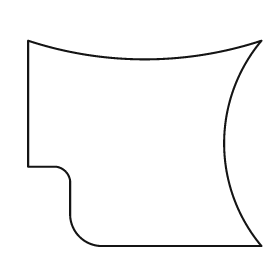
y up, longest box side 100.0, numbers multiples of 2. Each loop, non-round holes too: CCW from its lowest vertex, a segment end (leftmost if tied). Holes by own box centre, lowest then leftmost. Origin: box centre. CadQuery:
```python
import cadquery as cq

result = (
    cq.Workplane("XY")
    .moveTo(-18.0, -44.0)
    .lineTo(50.0, -44.0)
    .threePointArc((34.0, 0.0), (50.0, 44.0))
    .threePointArc((0.0, 36.0), (-50.0, 44.0))
    .lineTo(-50.0, -10.0)
    .lineTo(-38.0, -10.0)
    .threePointArc((-34.0, -12.0), (-32.0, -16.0))
    .lineTo(-32.0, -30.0)
    .threePointArc((-28.0, -40.0), (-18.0, -44.0))
    .close()
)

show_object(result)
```